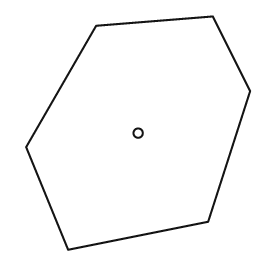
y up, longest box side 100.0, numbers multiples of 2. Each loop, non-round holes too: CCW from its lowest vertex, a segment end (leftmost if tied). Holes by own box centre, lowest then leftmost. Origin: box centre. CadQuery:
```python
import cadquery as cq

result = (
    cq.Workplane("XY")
    .moveTo(-30.0, -50.0)
    .lineTo(30.0, -38.0)
    .lineTo(48.0, 18.0)
    .lineTo(32.0, 50.0)
    .lineTo(-18.0, 46.0)
    .lineTo(-48.0, -6.0)
    .close()
    .moveTo(0.0, 0.0)
    .circle(2.0)
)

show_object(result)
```